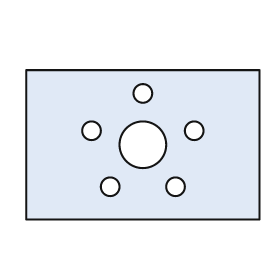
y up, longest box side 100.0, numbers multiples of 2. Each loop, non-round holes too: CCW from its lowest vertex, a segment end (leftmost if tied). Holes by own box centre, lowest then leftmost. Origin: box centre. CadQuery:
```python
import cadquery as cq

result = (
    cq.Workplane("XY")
    .moveTo(-50.0, -32.0)
    .lineTo(50.0, -32.0)
    .lineTo(50.0, 32.0)
    .lineTo(-50.0, 32.0)
    .close()
    .moveTo(-14.0, -18.0)
    .circle(4.0)
    .moveTo(14.0, -18.0)
    .circle(4.0)
    .moveTo(0.0, 0.0)
    .circle(10.0)
    .moveTo(-22.0, 6.0)
    .circle(4.0)
    .moveTo(22.0, 6.0)
    .circle(4.0)
    .moveTo(0.0, 22.0)
    .circle(4.0)
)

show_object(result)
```